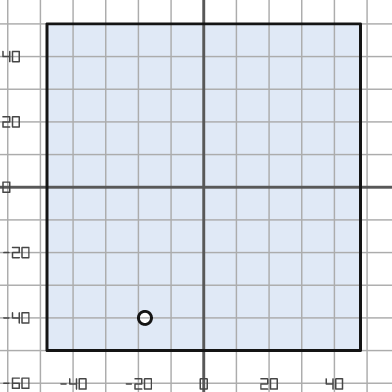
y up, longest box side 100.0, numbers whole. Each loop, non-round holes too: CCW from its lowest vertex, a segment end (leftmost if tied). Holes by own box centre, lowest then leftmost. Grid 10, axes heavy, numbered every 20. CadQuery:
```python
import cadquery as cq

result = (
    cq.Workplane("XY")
    .moveTo(-48.0, -50.0)
    .lineTo(48.0, -50.0)
    .lineTo(48.0, 50.0)
    .lineTo(-48.0, 50.0)
    .close()
    .moveTo(-18.0, -40.0)
    .circle(2.0)
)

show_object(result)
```